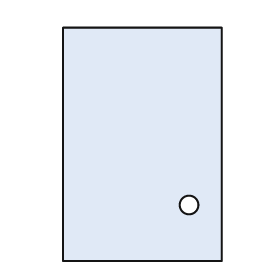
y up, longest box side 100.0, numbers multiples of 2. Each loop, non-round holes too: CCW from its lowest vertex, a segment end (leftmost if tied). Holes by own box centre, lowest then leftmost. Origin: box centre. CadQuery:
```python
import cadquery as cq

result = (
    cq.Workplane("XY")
    .moveTo(-34.0, -50.0)
    .lineTo(34.0, -50.0)
    .lineTo(34.0, 50.0)
    .lineTo(-34.0, 50.0)
    .close()
    .moveTo(20.0, -26.0)
    .circle(4.0)
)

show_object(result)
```